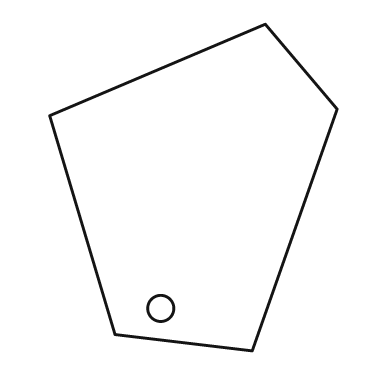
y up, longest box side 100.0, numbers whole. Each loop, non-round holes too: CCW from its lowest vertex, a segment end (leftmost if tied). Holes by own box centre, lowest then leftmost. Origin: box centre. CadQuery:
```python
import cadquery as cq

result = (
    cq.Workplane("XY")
    .moveTo(18.0, -50.0)
    .lineTo(44.0, 24.0)
    .lineTo(22.0, 50.0)
    .lineTo(-44.0, 22.0)
    .lineTo(-24.0, -45.0)
    .close()
    .moveTo(-10.0, -37.0)
    .circle(4.0)
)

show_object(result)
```